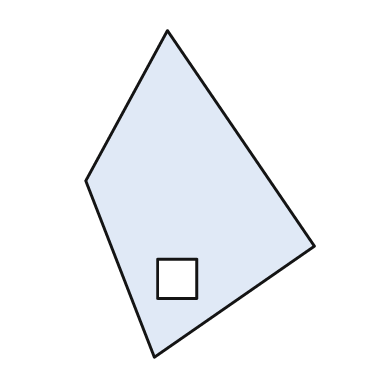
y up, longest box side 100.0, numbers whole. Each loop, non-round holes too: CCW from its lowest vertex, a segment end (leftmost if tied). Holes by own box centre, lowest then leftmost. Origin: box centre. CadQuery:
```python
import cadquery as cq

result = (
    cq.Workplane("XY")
    .moveTo(-14.0, -50.0)
    .lineTo(35.0, -16.0)
    .lineTo(-10.0, 50.0)
    .lineTo(-35.0, 4.0)
    .close()
    .moveTo(-13.0, -32.0)
    .lineTo(-1.0, -32.0)
    .lineTo(-1.0, -20.0)
    .lineTo(-13.0, -20.0)
    .close()
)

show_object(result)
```